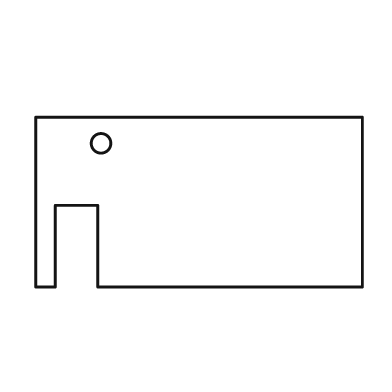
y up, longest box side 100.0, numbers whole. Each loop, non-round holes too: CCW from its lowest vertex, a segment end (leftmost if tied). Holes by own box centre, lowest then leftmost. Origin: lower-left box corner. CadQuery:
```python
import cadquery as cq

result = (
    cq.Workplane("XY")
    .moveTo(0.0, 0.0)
    .lineTo(6.0, 0.0)
    .lineTo(6.0, 25.0)
    .lineTo(19.0, 25.0)
    .lineTo(19.0, 0.0)
    .lineTo(100.0, 0.0)
    .lineTo(100.0, 52.0)
    .lineTo(0.0, 52.0)
    .close()
    .moveTo(20.0, 44.0)
    .circle(3.0)
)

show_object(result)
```